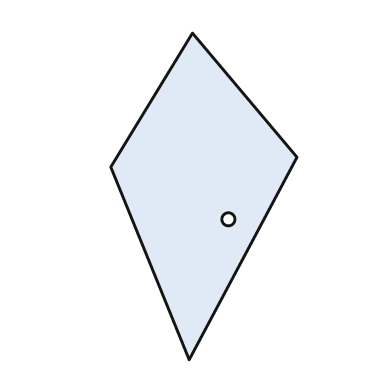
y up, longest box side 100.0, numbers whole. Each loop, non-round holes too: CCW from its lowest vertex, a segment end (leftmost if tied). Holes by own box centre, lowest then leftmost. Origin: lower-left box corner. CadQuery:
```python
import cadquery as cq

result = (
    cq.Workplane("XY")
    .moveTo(24.0, 0.0)
    .lineTo(57.0, 62.0)
    .lineTo(25.0, 100.0)
    .lineTo(0.0, 59.0)
    .close()
    .moveTo(36.0, 43.0)
    .circle(2.0)
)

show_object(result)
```